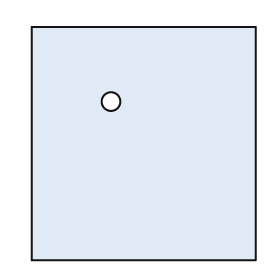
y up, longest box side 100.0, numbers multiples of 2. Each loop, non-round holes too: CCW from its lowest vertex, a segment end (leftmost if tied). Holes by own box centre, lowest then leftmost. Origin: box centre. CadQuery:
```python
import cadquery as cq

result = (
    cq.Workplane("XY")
    .moveTo(-48.0, -50.0)
    .lineTo(48.0, -50.0)
    .lineTo(48.0, 50.0)
    .lineTo(-48.0, 50.0)
    .close()
    .moveTo(-14.0, 18.0)
    .circle(4.0)
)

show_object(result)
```